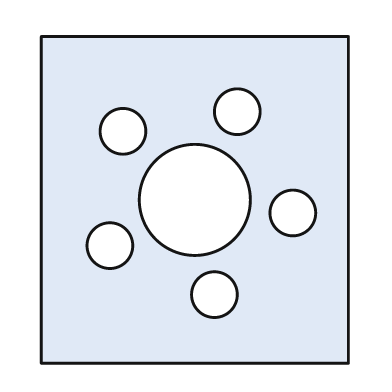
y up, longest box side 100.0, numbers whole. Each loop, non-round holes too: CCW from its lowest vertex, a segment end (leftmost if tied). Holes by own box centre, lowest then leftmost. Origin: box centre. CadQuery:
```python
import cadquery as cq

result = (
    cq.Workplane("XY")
    .moveTo(-47.0, -50.0)
    .lineTo(47.0, -50.0)
    .lineTo(47.0, 50.0)
    .lineTo(-47.0, 50.0)
    .close()
    .moveTo(6.0, -29.0)
    .circle(7.0)
    .moveTo(-26.0, -14.0)
    .circle(7.0)
    .moveTo(30.0, -4.0)
    .circle(7.0)
    .moveTo(0.0, 0.0)
    .circle(17.0)
    .moveTo(-22.0, 21.0)
    .circle(7.0)
    .moveTo(13.0, 27.0)
    .circle(7.0)
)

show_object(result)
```